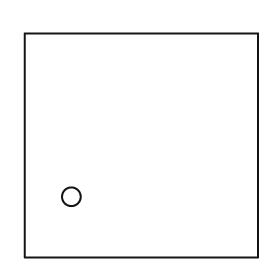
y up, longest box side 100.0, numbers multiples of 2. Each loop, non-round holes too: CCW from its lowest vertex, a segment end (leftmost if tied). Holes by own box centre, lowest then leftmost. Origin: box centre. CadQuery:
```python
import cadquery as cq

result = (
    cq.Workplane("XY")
    .moveTo(-50.0, -48.0)
    .lineTo(50.0, -48.0)
    .lineTo(50.0, 48.0)
    .lineTo(-50.0, 48.0)
    .close()
    .moveTo(-30.0, -22.0)
    .circle(4.0)
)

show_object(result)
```